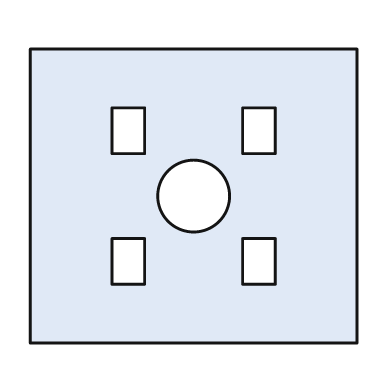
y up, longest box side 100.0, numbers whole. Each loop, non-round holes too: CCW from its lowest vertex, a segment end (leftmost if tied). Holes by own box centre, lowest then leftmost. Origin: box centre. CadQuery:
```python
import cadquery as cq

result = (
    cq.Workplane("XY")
    .moveTo(-50.0, -45.0)
    .lineTo(50.0, -45.0)
    .lineTo(50.0, 45.0)
    .lineTo(-50.0, 45.0)
    .close()
    .moveTo(-25.0, -27.0)
    .lineTo(-15.0, -27.0)
    .lineTo(-15.0, -13.0)
    .lineTo(-25.0, -13.0)
    .close()
    .moveTo(15.0, -27.0)
    .lineTo(25.0, -27.0)
    .lineTo(25.0, -13.0)
    .lineTo(15.0, -13.0)
    .close()
    .moveTo(0.0, 0.0)
    .circle(11.0)
    .moveTo(-25.0, 13.0)
    .lineTo(-15.0, 13.0)
    .lineTo(-15.0, 27.0)
    .lineTo(-25.0, 27.0)
    .close()
    .moveTo(15.0, 13.0)
    .lineTo(25.0, 13.0)
    .lineTo(25.0, 27.0)
    .lineTo(15.0, 27.0)
    .close()
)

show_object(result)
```